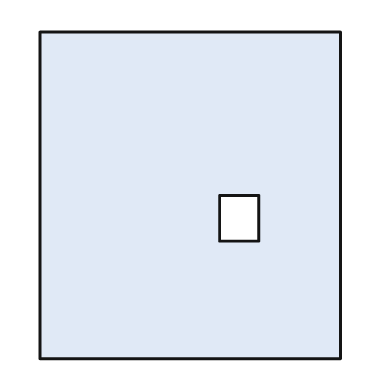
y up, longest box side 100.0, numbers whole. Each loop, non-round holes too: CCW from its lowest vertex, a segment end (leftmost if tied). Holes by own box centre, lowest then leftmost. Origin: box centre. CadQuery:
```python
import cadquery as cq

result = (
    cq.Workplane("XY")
    .moveTo(-46.0, -50.0)
    .lineTo(46.0, -50.0)
    .lineTo(46.0, 50.0)
    .lineTo(-46.0, 50.0)
    .close()
    .moveTo(9.0, -14.0)
    .lineTo(21.0, -14.0)
    .lineTo(21.0, 0.0)
    .lineTo(9.0, 0.0)
    .close()
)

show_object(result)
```